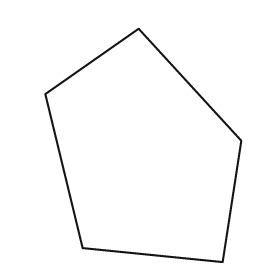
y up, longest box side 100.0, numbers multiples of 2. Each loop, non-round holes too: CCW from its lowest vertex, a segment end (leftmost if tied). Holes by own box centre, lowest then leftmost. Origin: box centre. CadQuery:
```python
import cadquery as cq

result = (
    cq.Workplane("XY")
    .moveTo(34.0, -50.0)
    .lineTo(42.0, 2.0)
    .lineTo(-2.0, 50.0)
    .lineTo(-42.0, 22.0)
    .lineTo(-26.0, -44.0)
    .close()
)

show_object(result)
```